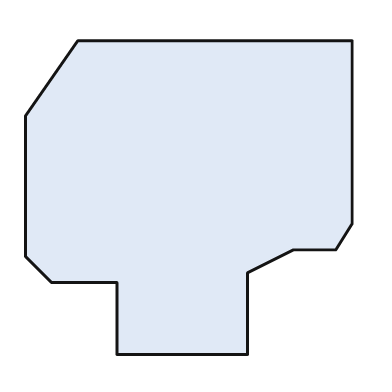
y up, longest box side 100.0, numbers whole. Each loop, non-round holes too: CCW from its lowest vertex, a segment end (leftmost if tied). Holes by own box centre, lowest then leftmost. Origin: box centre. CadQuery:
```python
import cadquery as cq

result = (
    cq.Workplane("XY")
    .moveTo(-22.0, -48.0)
    .lineTo(18.0, -48.0)
    .lineTo(18.0, -23.0)
    .lineTo(32.0, -16.0)
    .lineTo(45.0, -16.0)
    .lineTo(50.0, -8.0)
    .lineTo(50.0, 48.0)
    .lineTo(-34.0, 48.0)
    .lineTo(-50.0, 25.0)
    .lineTo(-50.0, -18.0)
    .lineTo(-42.0, -26.0)
    .lineTo(-22.0, -26.0)
    .close()
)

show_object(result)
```